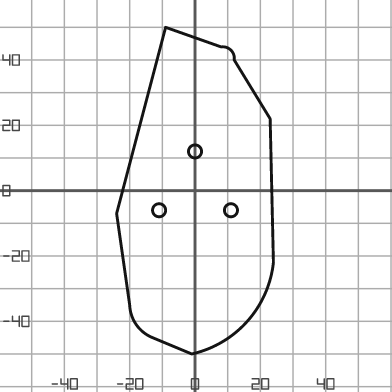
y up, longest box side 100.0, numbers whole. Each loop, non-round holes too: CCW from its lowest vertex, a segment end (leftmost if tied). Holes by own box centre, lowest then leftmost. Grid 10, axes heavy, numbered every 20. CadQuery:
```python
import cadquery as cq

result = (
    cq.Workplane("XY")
    .moveTo(-1.0, -50.0)
    .threePointArc((16.0, -40.0), (24.0, -22.0))
    .lineTo(23.0, 22.0)
    .lineTo(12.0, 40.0)
    .threePointArc((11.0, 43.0), (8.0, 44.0))
    .lineTo(-9.0, 50.0)
    .lineTo(-24.0, -7.0)
    .lineTo(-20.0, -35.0)
    .threePointArc((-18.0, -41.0), (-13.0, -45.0))
    .close()
    .moveTo(-11.0, -6.0)
    .circle(2.0)
    .moveTo(11.0, -6.0)
    .circle(2.0)
    .moveTo(0.0, 12.0)
    .circle(2.0)
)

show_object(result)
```